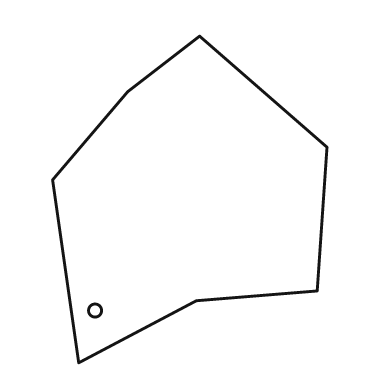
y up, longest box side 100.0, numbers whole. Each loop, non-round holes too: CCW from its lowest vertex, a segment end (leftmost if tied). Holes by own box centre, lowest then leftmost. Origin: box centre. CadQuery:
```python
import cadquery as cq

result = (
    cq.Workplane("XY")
    .moveTo(-34.0, -50.0)
    .lineTo(2.0, -31.0)
    .lineTo(39.0, -28.0)
    .lineTo(42.0, 16.0)
    .lineTo(3.0, 50.0)
    .lineTo(-19.0, 33.0)
    .lineTo(-42.0, 6.0)
    .close()
    .moveTo(-29.0, -34.0)
    .circle(2.0)
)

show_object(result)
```